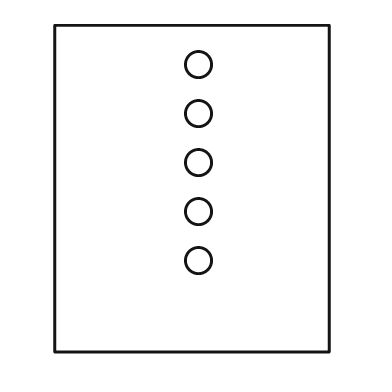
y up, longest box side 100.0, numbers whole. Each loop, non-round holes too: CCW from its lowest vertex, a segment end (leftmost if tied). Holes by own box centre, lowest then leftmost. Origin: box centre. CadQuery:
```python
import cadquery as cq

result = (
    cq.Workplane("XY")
    .moveTo(-42.0, -50.0)
    .lineTo(42.0, -50.0)
    .lineTo(42.0, 50.0)
    .lineTo(-42.0, 50.0)
    .close()
    .moveTo(2.0, -22.0)
    .circle(4.0)
    .moveTo(2.0, -7.0)
    .circle(4.0)
    .moveTo(2.0, 8.0)
    .circle(4.0)
    .moveTo(2.0, 23.0)
    .circle(4.0)
    .moveTo(2.0, 38.0)
    .circle(4.0)
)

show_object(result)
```